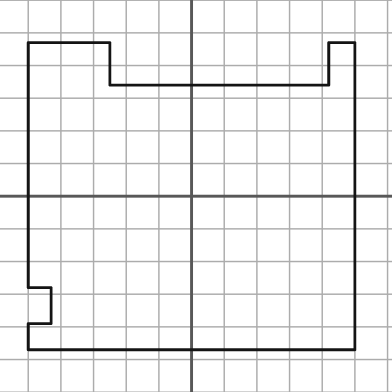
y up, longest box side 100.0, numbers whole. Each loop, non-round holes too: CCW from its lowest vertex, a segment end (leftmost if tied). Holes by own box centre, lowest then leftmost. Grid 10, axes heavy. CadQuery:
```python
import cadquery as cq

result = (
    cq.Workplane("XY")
    .moveTo(-50.0, -47.0)
    .lineTo(50.0, -47.0)
    .lineTo(50.0, 47.0)
    .lineTo(42.0, 47.0)
    .lineTo(42.0, 34.0)
    .lineTo(-25.0, 34.0)
    .lineTo(-25.0, 47.0)
    .lineTo(-50.0, 47.0)
    .lineTo(-50.0, -28.0)
    .lineTo(-43.0, -28.0)
    .lineTo(-43.0, -39.0)
    .lineTo(-50.0, -39.0)
    .close()
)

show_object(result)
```